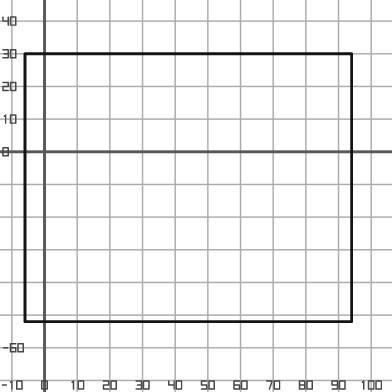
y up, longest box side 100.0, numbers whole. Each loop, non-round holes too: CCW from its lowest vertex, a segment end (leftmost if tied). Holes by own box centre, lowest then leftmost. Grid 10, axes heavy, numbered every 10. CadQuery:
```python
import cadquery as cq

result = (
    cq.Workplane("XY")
    .moveTo(-6.0, -52.0)
    .lineTo(94.0, -52.0)
    .lineTo(94.0, 30.0)
    .lineTo(-6.0, 30.0)
    .close()
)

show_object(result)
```